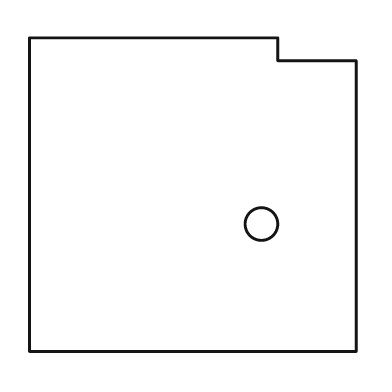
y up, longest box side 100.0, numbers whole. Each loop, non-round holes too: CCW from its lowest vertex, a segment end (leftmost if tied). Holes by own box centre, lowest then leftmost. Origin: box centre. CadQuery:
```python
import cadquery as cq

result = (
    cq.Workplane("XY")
    .moveTo(-50.0, -48.0)
    .lineTo(50.0, -48.0)
    .lineTo(50.0, 41.0)
    .lineTo(26.0, 41.0)
    .lineTo(26.0, 48.0)
    .lineTo(-50.0, 48.0)
    .close()
    .moveTo(21.0, -9.0)
    .circle(5.0)
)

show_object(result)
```